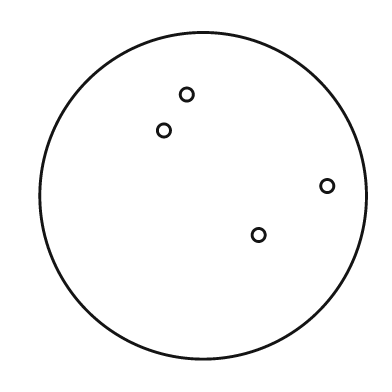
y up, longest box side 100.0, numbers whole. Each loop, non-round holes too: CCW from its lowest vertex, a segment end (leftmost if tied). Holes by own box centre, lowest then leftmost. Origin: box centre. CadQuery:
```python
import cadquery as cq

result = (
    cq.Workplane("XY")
    .moveTo(0.0, 0.0)
    .circle(50.0)
    .moveTo(17.0, -12.0)
    .circle(2.0)
    .moveTo(38.0, 3.0)
    .circle(2.0)
    .moveTo(-12.0, 20.0)
    .circle(2.0)
    .moveTo(-5.0, 31.0)
    .circle(2.0)
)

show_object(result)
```